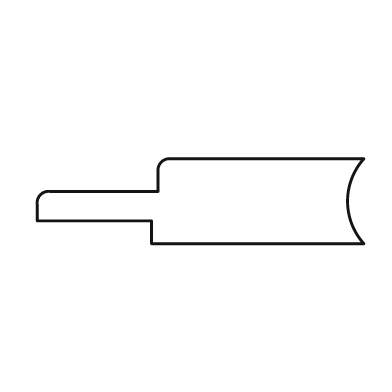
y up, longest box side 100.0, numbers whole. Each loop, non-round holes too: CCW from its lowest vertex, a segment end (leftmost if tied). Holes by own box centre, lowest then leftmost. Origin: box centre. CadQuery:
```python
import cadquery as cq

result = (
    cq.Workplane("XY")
    .moveTo(-15.0, -13.0)
    .lineTo(50.0, -13.0)
    .threePointArc((45.0, 0.0), (50.0, 13.0))
    .lineTo(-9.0, 13.0)
    .threePointArc((-12.0, 12.0), (-13.0, 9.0))
    .lineTo(-13.0, 3.0)
    .lineTo(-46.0, 3.0)
    .threePointArc((-49.0, 2.0), (-50.0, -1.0))
    .lineTo(-50.0, -6.0)
    .lineTo(-15.0, -6.0)
    .close()
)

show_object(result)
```